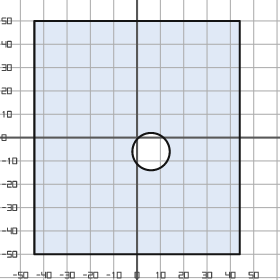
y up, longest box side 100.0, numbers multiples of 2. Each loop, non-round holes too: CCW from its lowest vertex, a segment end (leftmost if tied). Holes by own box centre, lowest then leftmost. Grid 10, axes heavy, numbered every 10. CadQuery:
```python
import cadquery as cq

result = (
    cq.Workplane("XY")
    .moveTo(-44.0, -50.0)
    .lineTo(44.0, -50.0)
    .lineTo(44.0, 50.0)
    .lineTo(-44.0, 50.0)
    .close()
    .moveTo(6.0, -6.0)
    .circle(8.0)
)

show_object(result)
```